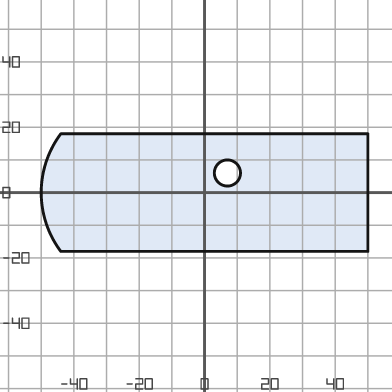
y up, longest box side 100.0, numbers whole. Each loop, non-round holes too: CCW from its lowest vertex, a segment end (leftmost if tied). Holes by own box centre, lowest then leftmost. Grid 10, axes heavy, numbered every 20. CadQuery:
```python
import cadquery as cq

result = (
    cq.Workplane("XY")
    .moveTo(-44.0, -18.0)
    .lineTo(50.0, -18.0)
    .lineTo(50.0, 18.0)
    .lineTo(-44.0, 18.0)
    .threePointArc((-50.0, 0.0), (-44.0, -18.0))
    .close()
    .moveTo(7.0, 6.0)
    .circle(4.0)
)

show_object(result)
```